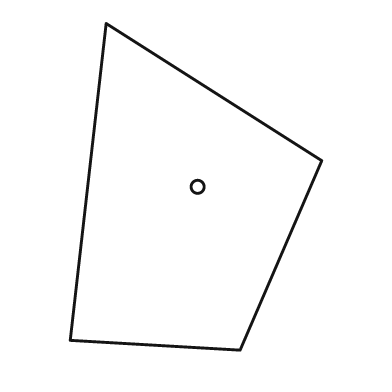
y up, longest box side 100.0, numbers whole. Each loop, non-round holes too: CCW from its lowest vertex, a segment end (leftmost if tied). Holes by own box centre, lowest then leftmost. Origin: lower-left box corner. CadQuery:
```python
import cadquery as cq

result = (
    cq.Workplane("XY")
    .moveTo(52.0, 0.0)
    .lineTo(77.0, 58.0)
    .lineTo(11.0, 100.0)
    .lineTo(0.0, 3.0)
    .close()
    .moveTo(39.0, 50.0)
    .circle(2.0)
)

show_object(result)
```